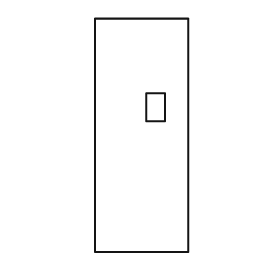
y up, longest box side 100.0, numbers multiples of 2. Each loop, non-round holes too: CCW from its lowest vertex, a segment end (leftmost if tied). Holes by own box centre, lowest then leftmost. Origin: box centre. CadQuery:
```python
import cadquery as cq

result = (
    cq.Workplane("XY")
    .moveTo(-20.0, -50.0)
    .lineTo(20.0, -50.0)
    .lineTo(20.0, 50.0)
    .lineTo(-20.0, 50.0)
    .close()
    .moveTo(2.0, 6.0)
    .lineTo(10.0, 6.0)
    .lineTo(10.0, 18.0)
    .lineTo(2.0, 18.0)
    .close()
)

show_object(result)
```